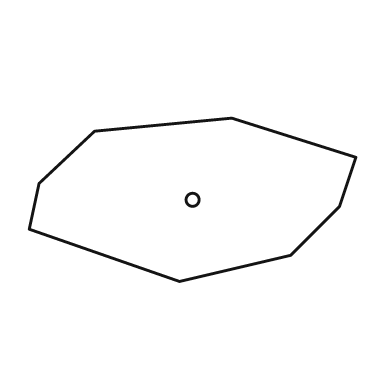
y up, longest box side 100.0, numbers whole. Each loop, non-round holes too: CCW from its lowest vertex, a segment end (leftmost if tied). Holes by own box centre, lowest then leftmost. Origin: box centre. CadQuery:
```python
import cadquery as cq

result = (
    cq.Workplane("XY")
    .moveTo(-4.0, -25.0)
    .lineTo(30.0, -17.0)
    .lineTo(45.0, -2.0)
    .lineTo(50.0, 13.0)
    .lineTo(12.0, 25.0)
    .lineTo(-30.0, 21.0)
    .lineTo(-47.0, 5.0)
    .lineTo(-50.0, -9.0)
    .close()
    .moveTo(0.0, 0.0)
    .circle(2.0)
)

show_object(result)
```